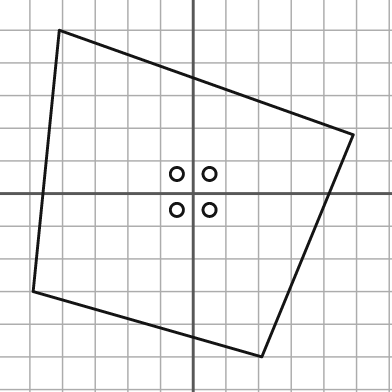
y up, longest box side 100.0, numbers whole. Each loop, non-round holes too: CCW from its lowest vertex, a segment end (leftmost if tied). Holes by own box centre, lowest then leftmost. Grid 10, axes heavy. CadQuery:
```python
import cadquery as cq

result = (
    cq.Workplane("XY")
    .moveTo(21.0, -50.0)
    .lineTo(49.0, 18.0)
    .lineTo(-41.0, 50.0)
    .lineTo(-49.0, -30.0)
    .close()
    .moveTo(-5.0, -5.0)
    .circle(2.0)
    .moveTo(5.0, -5.0)
    .circle(2.0)
    .moveTo(-5.0, 6.0)
    .circle(2.0)
    .moveTo(5.0, 6.0)
    .circle(2.0)
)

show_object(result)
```